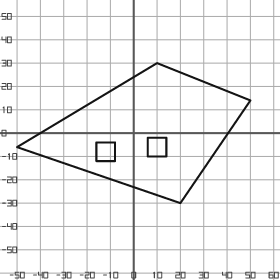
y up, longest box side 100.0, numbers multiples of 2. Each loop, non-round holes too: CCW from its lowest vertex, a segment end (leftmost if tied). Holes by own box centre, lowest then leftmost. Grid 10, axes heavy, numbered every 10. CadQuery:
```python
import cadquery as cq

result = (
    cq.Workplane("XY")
    .moveTo(20.0, -30.0)
    .lineTo(50.0, 14.0)
    .lineTo(10.0, 30.0)
    .lineTo(-50.0, -6.0)
    .close()
    .moveTo(-16.0, -12.0)
    .lineTo(-8.0, -12.0)
    .lineTo(-8.0, -4.0)
    .lineTo(-16.0, -4.0)
    .close()
    .moveTo(6.0, -10.0)
    .lineTo(14.0, -10.0)
    .lineTo(14.0, -2.0)
    .lineTo(6.0, -2.0)
    .close()
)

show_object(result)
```